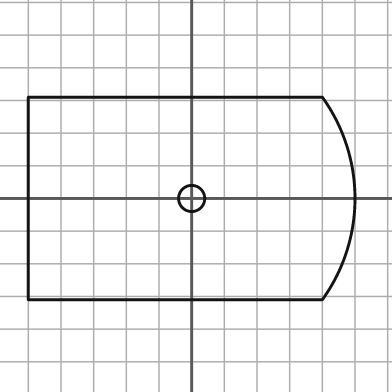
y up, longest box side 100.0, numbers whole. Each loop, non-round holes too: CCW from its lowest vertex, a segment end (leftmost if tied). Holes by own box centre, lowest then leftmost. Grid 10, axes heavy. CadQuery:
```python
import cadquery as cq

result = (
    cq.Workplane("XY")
    .moveTo(-50.0, -31.0)
    .lineTo(40.0, -31.0)
    .threePointArc((50.0, 0.0), (40.0, 31.0))
    .lineTo(-50.0, 31.0)
    .close()
    .moveTo(0.0, 0.0)
    .circle(4.0)
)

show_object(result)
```